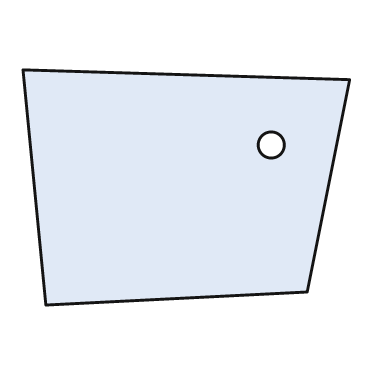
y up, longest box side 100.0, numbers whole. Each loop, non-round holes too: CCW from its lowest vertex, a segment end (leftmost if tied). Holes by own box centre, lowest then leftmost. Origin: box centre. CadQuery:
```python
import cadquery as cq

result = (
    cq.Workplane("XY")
    .moveTo(-43.0, -36.0)
    .lineTo(37.0, -32.0)
    .lineTo(50.0, 33.0)
    .lineTo(-50.0, 36.0)
    .close()
    .moveTo(26.0, 13.0)
    .circle(4.0)
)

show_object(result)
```